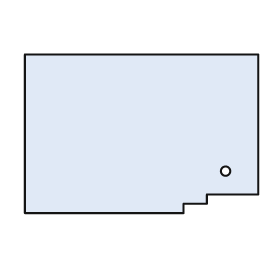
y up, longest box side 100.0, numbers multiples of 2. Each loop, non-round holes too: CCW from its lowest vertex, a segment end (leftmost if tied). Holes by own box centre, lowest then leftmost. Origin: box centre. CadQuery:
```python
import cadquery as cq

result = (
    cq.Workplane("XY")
    .moveTo(-50.0, -34.0)
    .lineTo(18.0, -34.0)
    .lineTo(18.0, -30.0)
    .lineTo(28.0, -30.0)
    .lineTo(28.0, -26.0)
    .lineTo(50.0, -26.0)
    .lineTo(50.0, 34.0)
    .lineTo(-50.0, 34.0)
    .close()
    .moveTo(36.0, -16.0)
    .circle(2.0)
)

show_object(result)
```